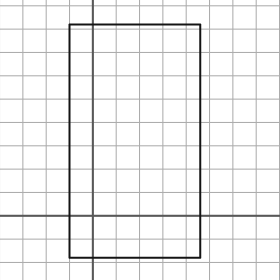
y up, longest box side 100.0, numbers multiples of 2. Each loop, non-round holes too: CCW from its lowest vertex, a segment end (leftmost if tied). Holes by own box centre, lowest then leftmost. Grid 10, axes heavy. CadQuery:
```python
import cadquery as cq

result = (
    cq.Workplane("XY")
    .moveTo(-10.0, -18.0)
    .lineTo(46.0, -18.0)
    .lineTo(46.0, 82.0)
    .lineTo(-10.0, 82.0)
    .close()
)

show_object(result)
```